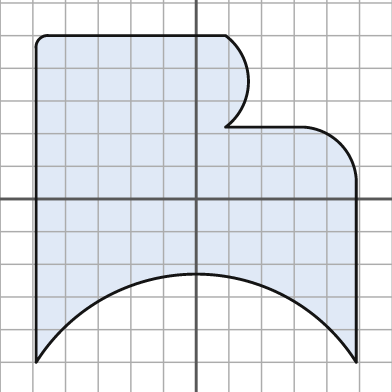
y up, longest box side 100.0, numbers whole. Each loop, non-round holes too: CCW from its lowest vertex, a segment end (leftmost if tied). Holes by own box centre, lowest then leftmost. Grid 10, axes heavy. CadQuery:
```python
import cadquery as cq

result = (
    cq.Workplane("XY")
    .moveTo(-49.0, -50.0)
    .threePointArc((0.0, -23.0), (49.0, -50.0))
    .lineTo(49.0, 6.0)
    .threePointArc((44.0, 17.0), (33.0, 22.0))
    .lineTo(9.0, 22.0)
    .threePointArc((16.0, 36.0), (9.0, 50.0))
    .lineTo(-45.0, 50.0)
    .threePointArc((-48.0, 49.0), (-49.0, 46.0))
    .close()
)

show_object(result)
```